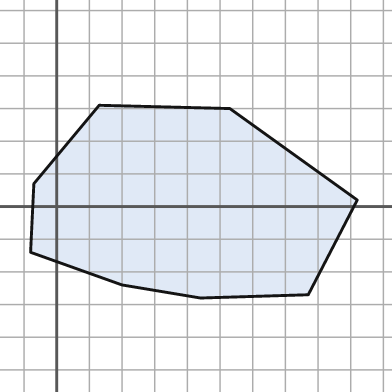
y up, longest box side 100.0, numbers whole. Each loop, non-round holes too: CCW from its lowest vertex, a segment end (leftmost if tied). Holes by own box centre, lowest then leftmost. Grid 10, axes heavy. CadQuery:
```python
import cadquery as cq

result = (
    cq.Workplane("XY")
    .moveTo(44.0, -28.0)
    .lineTo(77.0, -27.0)
    .lineTo(92.0, 2.0)
    .lineTo(53.0, 30.0)
    .lineTo(13.0, 31.0)
    .lineTo(-7.0, 7.0)
    .lineTo(-8.0, -14.0)
    .lineTo(20.0, -24.0)
    .close()
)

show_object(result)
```